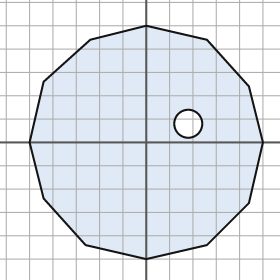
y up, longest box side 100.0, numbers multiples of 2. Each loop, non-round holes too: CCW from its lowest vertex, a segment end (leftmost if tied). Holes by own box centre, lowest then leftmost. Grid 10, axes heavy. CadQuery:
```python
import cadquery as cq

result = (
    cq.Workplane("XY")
    .moveTo(0.0, -50.0)
    .lineTo(26.0, -44.0)
    .lineTo(44.0, -26.0)
    .lineTo(50.0, 0.0)
    .lineTo(44.0, 24.0)
    .lineTo(26.0, 44.0)
    .lineTo(0.0, 50.0)
    .lineTo(-24.0, 44.0)
    .lineTo(-44.0, 26.0)
    .lineTo(-50.0, 0.0)
    .lineTo(-44.0, -24.0)
    .lineTo(-26.0, -44.0)
    .close()
    .moveTo(18.0, 8.0)
    .circle(6.0)
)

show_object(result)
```